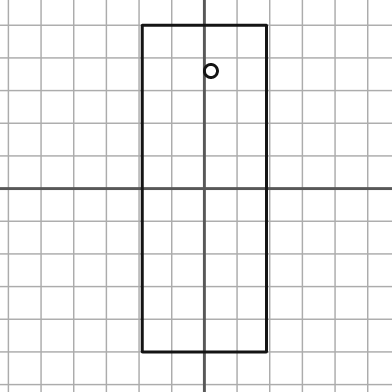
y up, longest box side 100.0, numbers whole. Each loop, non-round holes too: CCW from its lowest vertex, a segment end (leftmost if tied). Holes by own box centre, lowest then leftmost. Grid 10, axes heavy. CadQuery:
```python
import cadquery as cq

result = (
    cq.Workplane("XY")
    .moveTo(-19.0, -50.0)
    .lineTo(19.0, -50.0)
    .lineTo(19.0, 50.0)
    .lineTo(-19.0, 50.0)
    .close()
    .moveTo(2.0, 36.0)
    .circle(2.0)
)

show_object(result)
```